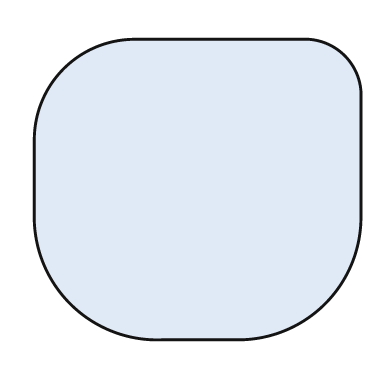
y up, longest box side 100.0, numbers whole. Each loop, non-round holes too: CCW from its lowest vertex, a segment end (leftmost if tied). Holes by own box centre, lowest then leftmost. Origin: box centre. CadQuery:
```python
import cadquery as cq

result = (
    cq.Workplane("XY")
    .moveTo(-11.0, -46.0)
    .lineTo(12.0, -46.0)
    .threePointArc((39.0, -35.0), (50.0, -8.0))
    .lineTo(50.0, 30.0)
    .threePointArc((45.0, 41.0), (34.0, 46.0))
    .lineTo(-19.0, 46.0)
    .threePointArc((-41.0, 37.0), (-50.0, 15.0))
    .lineTo(-50.0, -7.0)
    .threePointArc((-39.0, -35.0), (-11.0, -46.0))
    .close()
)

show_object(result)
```